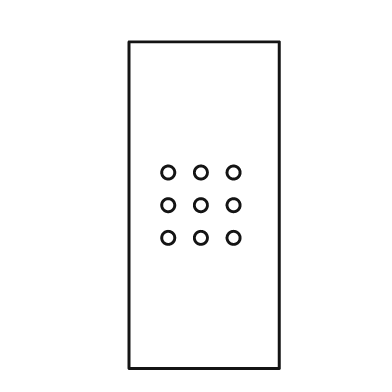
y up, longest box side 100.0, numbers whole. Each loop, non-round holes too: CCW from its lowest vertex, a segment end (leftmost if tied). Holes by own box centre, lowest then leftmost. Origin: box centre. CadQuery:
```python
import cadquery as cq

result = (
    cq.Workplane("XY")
    .moveTo(-23.0, -50.0)
    .lineTo(23.0, -50.0)
    .lineTo(23.0, 50.0)
    .lineTo(-23.0, 50.0)
    .close()
    .moveTo(-11.0, -10.0)
    .circle(2.0)
    .moveTo(-1.0, -10.0)
    .circle(2.0)
    .moveTo(9.0, -10.0)
    .circle(2.0)
    .moveTo(-11.0, 0.0)
    .circle(2.0)
    .moveTo(-1.0, 0.0)
    .circle(2.0)
    .moveTo(9.0, 0.0)
    .circle(2.0)
    .moveTo(-11.0, 10.0)
    .circle(2.0)
    .moveTo(-1.0, 10.0)
    .circle(2.0)
    .moveTo(9.0, 10.0)
    .circle(2.0)
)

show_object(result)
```